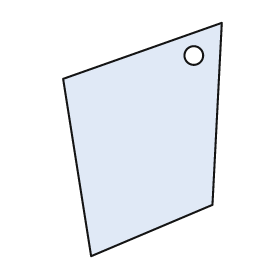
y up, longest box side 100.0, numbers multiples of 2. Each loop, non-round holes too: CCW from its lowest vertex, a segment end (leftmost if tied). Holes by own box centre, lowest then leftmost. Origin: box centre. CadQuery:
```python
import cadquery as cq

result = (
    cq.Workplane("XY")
    .moveTo(-22.0, -50.0)
    .lineTo(30.0, -28.0)
    .lineTo(34.0, 50.0)
    .lineTo(-34.0, 26.0)
    .close()
    .moveTo(22.0, 36.0)
    .circle(4.0)
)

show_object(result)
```